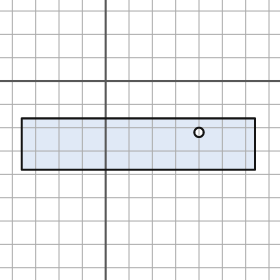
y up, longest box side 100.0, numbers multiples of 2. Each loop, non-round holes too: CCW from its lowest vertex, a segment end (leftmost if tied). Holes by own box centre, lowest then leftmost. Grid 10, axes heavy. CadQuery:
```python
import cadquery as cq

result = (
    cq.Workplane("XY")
    .moveTo(-36.0, -38.0)
    .lineTo(64.0, -38.0)
    .lineTo(64.0, -16.0)
    .lineTo(-36.0, -16.0)
    .close()
    .moveTo(40.0, -22.0)
    .circle(2.0)
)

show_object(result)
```